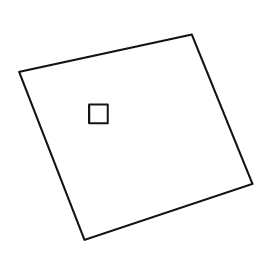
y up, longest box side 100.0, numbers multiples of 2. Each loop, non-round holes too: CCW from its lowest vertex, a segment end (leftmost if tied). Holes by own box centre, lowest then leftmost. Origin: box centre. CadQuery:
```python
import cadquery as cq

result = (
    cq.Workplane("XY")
    .moveTo(-22.0, -44.0)
    .lineTo(50.0, -20.0)
    .lineTo(24.0, 44.0)
    .lineTo(-50.0, 28.0)
    .close()
    .moveTo(-20.0, 6.0)
    .lineTo(-12.0, 6.0)
    .lineTo(-12.0, 14.0)
    .lineTo(-20.0, 14.0)
    .close()
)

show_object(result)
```